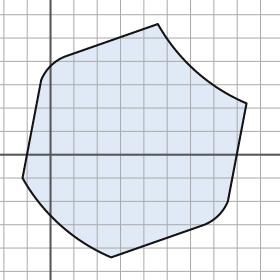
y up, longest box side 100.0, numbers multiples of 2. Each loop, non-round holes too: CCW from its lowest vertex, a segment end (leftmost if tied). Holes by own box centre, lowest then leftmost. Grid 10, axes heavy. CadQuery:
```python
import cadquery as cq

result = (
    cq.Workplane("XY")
    .moveTo(26.0, -44.0)
    .lineTo(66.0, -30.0)
    .threePointArc((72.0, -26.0), (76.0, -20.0))
    .lineTo(84.0, 22.0)
    .threePointArc((62.0, 36.0), (46.0, 56.0))
    .lineTo(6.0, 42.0)
    .threePointArc((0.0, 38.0), (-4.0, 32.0))
    .lineTo(-12.0, -10.0)
    .threePointArc((4.0, -30.0), (26.0, -44.0))
    .close()
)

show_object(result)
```